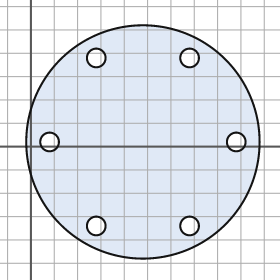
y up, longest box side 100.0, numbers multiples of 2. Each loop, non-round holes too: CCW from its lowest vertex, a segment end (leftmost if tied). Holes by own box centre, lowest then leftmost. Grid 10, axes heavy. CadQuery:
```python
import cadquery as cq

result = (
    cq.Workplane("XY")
    .moveTo(48.0, 2.0)
    .circle(50.0)
    .moveTo(28.0, -34.0)
    .circle(4.0)
    .moveTo(68.0, -34.0)
    .circle(4.0)
    .moveTo(8.0, 2.0)
    .circle(4.0)
    .moveTo(88.0, 2.0)
    .circle(4.0)
    .moveTo(28.0, 38.0)
    .circle(4.0)
    .moveTo(68.0, 38.0)
    .circle(4.0)
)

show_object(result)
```